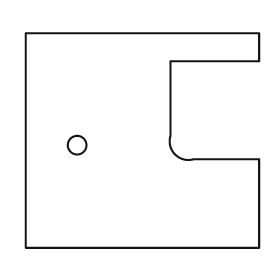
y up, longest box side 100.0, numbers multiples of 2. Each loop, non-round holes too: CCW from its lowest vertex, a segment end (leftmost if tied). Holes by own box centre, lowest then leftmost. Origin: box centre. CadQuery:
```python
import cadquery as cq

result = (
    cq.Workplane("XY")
    .moveTo(-50.0, -46.0)
    .lineTo(50.0, -46.0)
    .lineTo(50.0, -8.0)
    .lineTo(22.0, -8.0)
    .threePointArc((14.0, -6.0), (12.0, 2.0))
    .lineTo(12.0, 34.0)
    .lineTo(50.0, 34.0)
    .lineTo(50.0, 46.0)
    .lineTo(-50.0, 46.0)
    .close()
    .moveTo(-28.0, -2.0)
    .circle(4.0)
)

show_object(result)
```